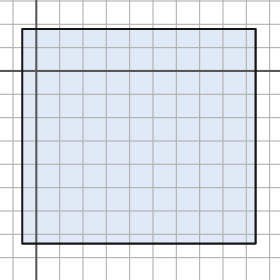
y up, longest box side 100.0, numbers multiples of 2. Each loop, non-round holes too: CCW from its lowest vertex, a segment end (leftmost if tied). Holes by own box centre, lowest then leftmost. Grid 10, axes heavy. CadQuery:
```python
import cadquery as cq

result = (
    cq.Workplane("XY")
    .moveTo(-6.0, -74.0)
    .lineTo(94.0, -74.0)
    .lineTo(94.0, 18.0)
    .lineTo(-6.0, 18.0)
    .close()
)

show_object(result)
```